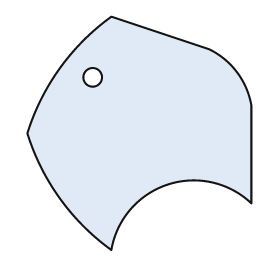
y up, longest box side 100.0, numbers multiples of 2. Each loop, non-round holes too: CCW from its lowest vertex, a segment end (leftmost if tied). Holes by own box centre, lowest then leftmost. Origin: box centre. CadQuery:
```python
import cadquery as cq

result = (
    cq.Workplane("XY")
    .moveTo(-12.0, -50.0)
    .threePointArc((12.0, -22.0), (48.0, -30.0))
    .lineTo(48.0, 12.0)
    .threePointArc((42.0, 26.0), (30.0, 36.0))
    .lineTo(-12.0, 50.0)
    .threePointArc((-34.0, 28.0), (-48.0, 0.0))
    .threePointArc((-34.0, -28.0), (-12.0, -50.0))
    .close()
    .moveTo(-20.0, 24.0)
    .circle(4.0)
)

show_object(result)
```